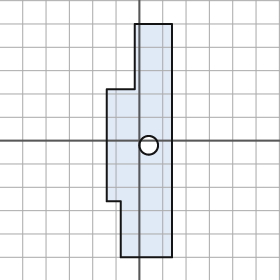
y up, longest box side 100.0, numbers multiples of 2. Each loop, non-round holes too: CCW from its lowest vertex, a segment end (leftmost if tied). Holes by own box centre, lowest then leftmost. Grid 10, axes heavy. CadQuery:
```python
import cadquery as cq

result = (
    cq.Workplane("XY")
    .moveTo(-8.0, -50.0)
    .lineTo(14.0, -50.0)
    .lineTo(14.0, 50.0)
    .lineTo(-2.0, 50.0)
    .lineTo(-2.0, 22.0)
    .lineTo(-14.0, 22.0)
    .lineTo(-14.0, -26.0)
    .lineTo(-8.0, -26.0)
    .close()
    .moveTo(4.0, -2.0)
    .circle(4.0)
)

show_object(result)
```